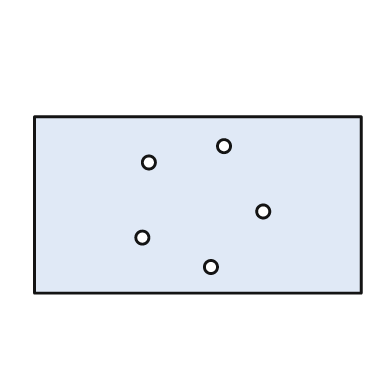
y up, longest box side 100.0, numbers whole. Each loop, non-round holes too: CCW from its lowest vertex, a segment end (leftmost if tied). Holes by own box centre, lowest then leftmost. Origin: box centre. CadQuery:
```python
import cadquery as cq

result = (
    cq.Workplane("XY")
    .moveTo(-50.0, -27.0)
    .lineTo(50.0, -27.0)
    .lineTo(50.0, 27.0)
    .lineTo(-50.0, 27.0)
    .close()
    .moveTo(4.0, -19.0)
    .circle(2.0)
    .moveTo(-17.0, -10.0)
    .circle(2.0)
    .moveTo(20.0, -2.0)
    .circle(2.0)
    .moveTo(-15.0, 13.0)
    .circle(2.0)
    .moveTo(8.0, 18.0)
    .circle(2.0)
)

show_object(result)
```